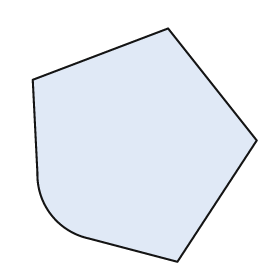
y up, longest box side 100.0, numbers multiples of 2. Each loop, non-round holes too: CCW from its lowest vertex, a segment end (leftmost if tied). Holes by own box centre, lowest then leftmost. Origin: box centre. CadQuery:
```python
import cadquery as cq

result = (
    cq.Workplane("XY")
    .moveTo(14.0, -50.0)
    .lineTo(48.0, 2.0)
    .lineTo(10.0, 50.0)
    .lineTo(-48.0, 28.0)
    .lineTo(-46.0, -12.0)
    .threePointArc((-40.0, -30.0), (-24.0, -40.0))
    .close()
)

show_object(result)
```